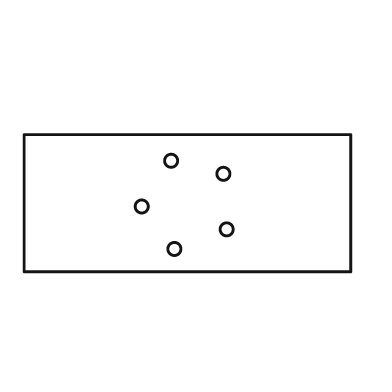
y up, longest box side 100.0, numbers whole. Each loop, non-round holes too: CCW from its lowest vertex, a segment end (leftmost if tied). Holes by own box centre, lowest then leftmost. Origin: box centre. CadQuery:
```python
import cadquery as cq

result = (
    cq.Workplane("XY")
    .moveTo(-50.0, -21.0)
    .lineTo(50.0, -21.0)
    .lineTo(50.0, 21.0)
    .lineTo(-50.0, 21.0)
    .close()
    .moveTo(-4.0, -14.0)
    .circle(2.0)
    .moveTo(12.0, -8.0)
    .circle(2.0)
    .moveTo(-14.0, -1.0)
    .circle(2.0)
    .moveTo(11.0, 9.0)
    .circle(2.0)
    .moveTo(-5.0, 13.0)
    .circle(2.0)
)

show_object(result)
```